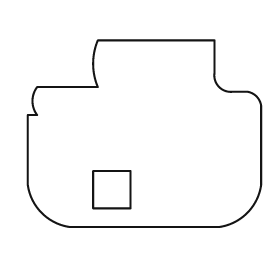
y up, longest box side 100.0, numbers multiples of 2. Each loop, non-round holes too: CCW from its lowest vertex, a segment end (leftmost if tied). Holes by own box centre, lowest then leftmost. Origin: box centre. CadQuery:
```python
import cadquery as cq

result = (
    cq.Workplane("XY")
    .moveTo(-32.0, -40.0)
    .lineTo(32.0, -40.0)
    .threePointArc((44.0, -34.0), (50.0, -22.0))
    .lineTo(50.0, 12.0)
    .threePointArc((48.0, 16.0), (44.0, 18.0))
    .lineTo(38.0, 18.0)
    .threePointArc((32.0, 20.0), (30.0, 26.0))
    .lineTo(30.0, 40.0)
    .lineTo(-20.0, 40.0)
    .threePointArc((-22.0, 30.0), (-20.0, 20.0))
    .lineTo(-46.0, 20.0)
    .threePointArc((-48.0, 14.0), (-46.0, 8.0))
    .lineTo(-50.0, 8.0)
    .lineTo(-50.0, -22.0)
    .threePointArc((-44.0, -34.0), (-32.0, -40.0))
    .close()
    .moveTo(-22.0, -32.0)
    .lineTo(-6.0, -32.0)
    .lineTo(-6.0, -16.0)
    .lineTo(-22.0, -16.0)
    .close()
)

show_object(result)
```